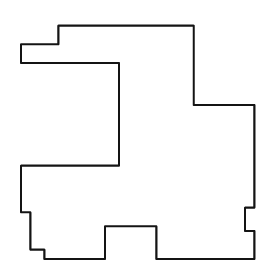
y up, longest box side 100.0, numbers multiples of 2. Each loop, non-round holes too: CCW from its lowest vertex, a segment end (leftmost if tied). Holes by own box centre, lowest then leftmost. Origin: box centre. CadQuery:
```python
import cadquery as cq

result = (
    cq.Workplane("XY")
    .moveTo(-40.0, -50.0)
    .lineTo(-14.0, -50.0)
    .lineTo(-14.0, -36.0)
    .lineTo(8.0, -36.0)
    .lineTo(8.0, -50.0)
    .lineTo(50.0, -50.0)
    .lineTo(50.0, -38.0)
    .lineTo(46.0, -38.0)
    .lineTo(46.0, -28.0)
    .lineTo(50.0, -28.0)
    .lineTo(50.0, 16.0)
    .lineTo(24.0, 16.0)
    .lineTo(24.0, 50.0)
    .lineTo(-34.0, 50.0)
    .lineTo(-34.0, 42.0)
    .lineTo(-50.0, 42.0)
    .lineTo(-50.0, 34.0)
    .lineTo(-8.0, 34.0)
    .lineTo(-8.0, -10.0)
    .lineTo(-50.0, -10.0)
    .lineTo(-50.0, -30.0)
    .lineTo(-46.0, -30.0)
    .lineTo(-46.0, -46.0)
    .lineTo(-40.0, -46.0)
    .close()
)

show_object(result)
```